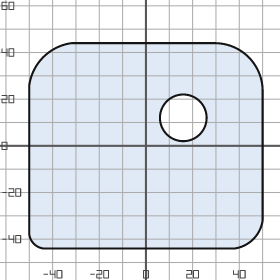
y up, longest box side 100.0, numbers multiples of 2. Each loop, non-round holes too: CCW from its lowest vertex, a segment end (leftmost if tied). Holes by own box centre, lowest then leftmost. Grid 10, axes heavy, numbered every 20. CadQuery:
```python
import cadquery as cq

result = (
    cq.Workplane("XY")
    .moveTo(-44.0, -44.0)
    .lineTo(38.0, -44.0)
    .threePointArc((46.0, -40.0), (50.0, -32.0))
    .lineTo(50.0, 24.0)
    .threePointArc((44.0, 38.0), (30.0, 44.0))
    .lineTo(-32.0, 44.0)
    .threePointArc((-44.0, 38.0), (-50.0, 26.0))
    .lineTo(-50.0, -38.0)
    .threePointArc((-48.0, -42.0), (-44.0, -44.0))
    .close()
    .moveTo(16.0, 12.0)
    .circle(10.0)
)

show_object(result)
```